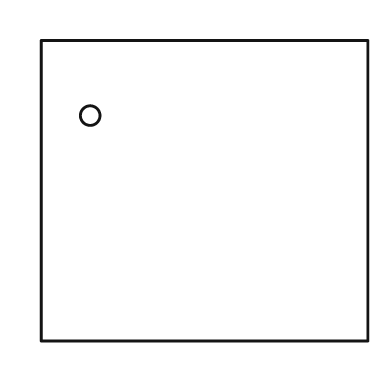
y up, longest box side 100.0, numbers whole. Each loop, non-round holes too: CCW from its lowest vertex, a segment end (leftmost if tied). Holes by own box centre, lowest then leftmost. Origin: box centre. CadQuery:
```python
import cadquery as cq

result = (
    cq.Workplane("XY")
    .moveTo(-50.0, -46.0)
    .lineTo(50.0, -46.0)
    .lineTo(50.0, 46.0)
    .lineTo(-50.0, 46.0)
    .close()
    .moveTo(-35.0, 23.0)
    .circle(3.0)
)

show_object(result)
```